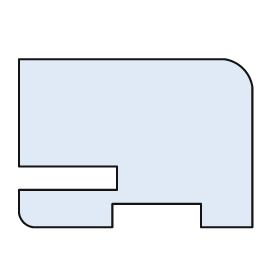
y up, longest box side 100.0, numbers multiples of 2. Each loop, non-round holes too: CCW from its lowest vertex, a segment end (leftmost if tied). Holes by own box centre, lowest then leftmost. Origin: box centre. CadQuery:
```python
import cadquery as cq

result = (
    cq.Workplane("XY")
    .moveTo(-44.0, -36.0)
    .lineTo(-10.0, -36.0)
    .lineTo(-10.0, -26.0)
    .lineTo(28.0, -26.0)
    .lineTo(28.0, -36.0)
    .lineTo(50.0, -36.0)
    .lineTo(50.0, 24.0)
    .threePointArc((46.0, 32.0), (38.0, 36.0))
    .lineTo(-50.0, 36.0)
    .lineTo(-50.0, -10.0)
    .lineTo(-8.0, -10.0)
    .lineTo(-8.0, -20.0)
    .lineTo(-50.0, -20.0)
    .lineTo(-50.0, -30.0)
    .threePointArc((-48.0, -34.0), (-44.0, -36.0))
    .close()
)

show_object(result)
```